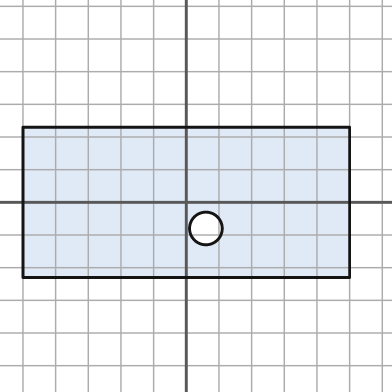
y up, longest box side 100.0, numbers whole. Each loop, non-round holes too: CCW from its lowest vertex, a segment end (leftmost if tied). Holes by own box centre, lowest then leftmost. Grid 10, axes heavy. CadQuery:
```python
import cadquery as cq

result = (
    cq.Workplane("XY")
    .moveTo(-50.0, -23.0)
    .lineTo(50.0, -23.0)
    .lineTo(50.0, 23.0)
    .lineTo(-50.0, 23.0)
    .close()
    .moveTo(6.0, -8.0)
    .circle(5.0)
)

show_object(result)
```